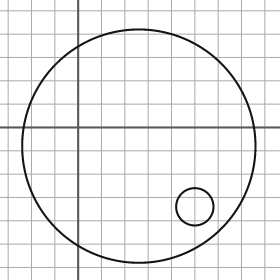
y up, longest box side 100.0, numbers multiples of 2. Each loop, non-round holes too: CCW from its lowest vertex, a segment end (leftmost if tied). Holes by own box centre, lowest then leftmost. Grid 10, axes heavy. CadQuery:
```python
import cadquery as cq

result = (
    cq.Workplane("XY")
    .moveTo(26.0, -8.0)
    .circle(50.0)
    .moveTo(50.0, -34.0)
    .circle(8.0)
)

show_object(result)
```